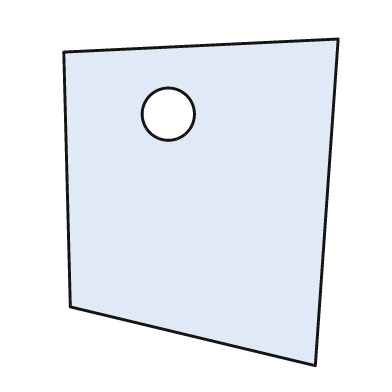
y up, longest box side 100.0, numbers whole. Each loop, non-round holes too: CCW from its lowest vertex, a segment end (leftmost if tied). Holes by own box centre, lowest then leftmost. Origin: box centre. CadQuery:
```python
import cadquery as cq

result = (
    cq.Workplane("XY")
    .moveTo(35.0, -50.0)
    .lineTo(42.0, 50.0)
    .lineTo(-42.0, 46.0)
    .lineTo(-40.0, -32.0)
    .close()
    .moveTo(-10.0, 27.0)
    .circle(8.0)
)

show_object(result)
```